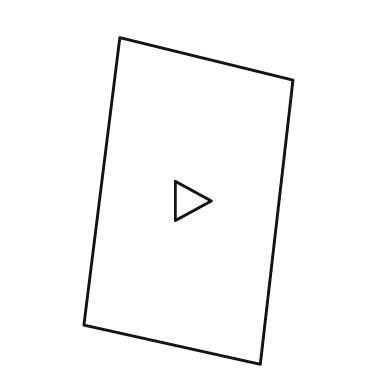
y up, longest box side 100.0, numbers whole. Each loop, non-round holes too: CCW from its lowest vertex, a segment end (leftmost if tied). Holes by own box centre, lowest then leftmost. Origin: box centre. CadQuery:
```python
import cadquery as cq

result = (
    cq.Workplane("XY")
    .moveTo(22.0, -50.0)
    .lineTo(32.0, 37.0)
    .lineTo(-21.0, 50.0)
    .lineTo(-32.0, -38.0)
    .close()
    .moveTo(-4.0, -6.0)
    .lineTo(7.0, 0.0)
    .lineTo(-4.0, 6.0)
    .close()
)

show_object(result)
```